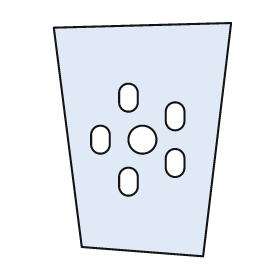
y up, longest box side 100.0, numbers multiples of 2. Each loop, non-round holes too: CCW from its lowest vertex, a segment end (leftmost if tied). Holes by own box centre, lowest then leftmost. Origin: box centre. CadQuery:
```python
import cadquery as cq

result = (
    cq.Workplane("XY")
    .moveTo(26.0, -50.0)
    .lineTo(38.0, 50.0)
    .lineTo(-38.0, 48.0)
    .lineTo(-26.0, -46.0)
    .close()
    .moveTo(-10.0, -20.0)
    .threePointArc((-6.0, -24.0), (-2.0, -20.0))
    .lineTo(-2.0, -16.0)
    .threePointArc((-6.0, -12.0), (-10.0, -16.0))
    .close()
    .moveTo(10.0, -12.0)
    .threePointArc((14.0, -16.0), (18.0, -12.0))
    .lineTo(18.0, -8.0)
    .threePointArc((14.0, -4.0), (10.0, -8.0))
    .close()
    .moveTo(-22.0, -2.0)
    .threePointArc((-18.0, -6.0), (-14.0, -2.0))
    .lineTo(-14.0, 2.0)
    .threePointArc((-18.0, 6.0), (-22.0, 2.0))
    .close()
    .moveTo(0.0, 0.0)
    .circle(6.0)
    .moveTo(10.0, 8.0)
    .threePointArc((14.0, 4.0), (18.0, 8.0))
    .lineTo(18.0, 12.0)
    .threePointArc((14.0, 16.0), (10.0, 12.0))
    .close()
    .moveTo(-10.0, 16.0)
    .threePointArc((-6.0, 12.0), (-2.0, 16.0))
    .lineTo(-2.0, 20.0)
    .threePointArc((-6.0, 24.0), (-10.0, 20.0))
    .close()
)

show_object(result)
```